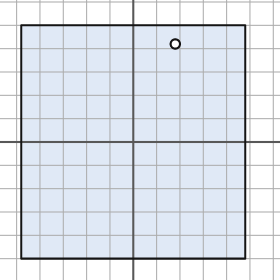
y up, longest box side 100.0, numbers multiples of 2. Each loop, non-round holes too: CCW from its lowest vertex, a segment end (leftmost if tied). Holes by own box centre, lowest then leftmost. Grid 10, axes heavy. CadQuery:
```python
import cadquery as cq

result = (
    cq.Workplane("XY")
    .moveTo(-48.0, -50.0)
    .lineTo(48.0, -50.0)
    .lineTo(48.0, 50.0)
    .lineTo(-48.0, 50.0)
    .close()
    .moveTo(18.0, 42.0)
    .circle(2.0)
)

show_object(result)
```